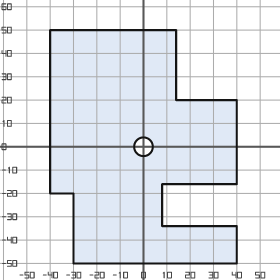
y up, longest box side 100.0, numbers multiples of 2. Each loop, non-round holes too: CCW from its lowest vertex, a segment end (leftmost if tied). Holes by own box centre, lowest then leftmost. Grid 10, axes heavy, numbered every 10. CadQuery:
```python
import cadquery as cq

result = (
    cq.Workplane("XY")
    .moveTo(-30.0, -50.0)
    .lineTo(40.0, -50.0)
    .lineTo(40.0, -34.0)
    .lineTo(8.0, -34.0)
    .lineTo(8.0, -16.0)
    .lineTo(40.0, -16.0)
    .lineTo(40.0, 20.0)
    .lineTo(14.0, 20.0)
    .lineTo(14.0, 50.0)
    .lineTo(-40.0, 50.0)
    .lineTo(-40.0, -20.0)
    .lineTo(-30.0, -20.0)
    .close()
    .moveTo(0.0, 0.0)
    .circle(4.0)
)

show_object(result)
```